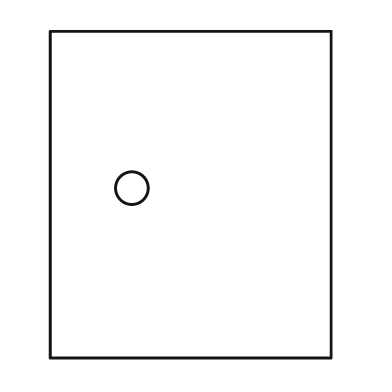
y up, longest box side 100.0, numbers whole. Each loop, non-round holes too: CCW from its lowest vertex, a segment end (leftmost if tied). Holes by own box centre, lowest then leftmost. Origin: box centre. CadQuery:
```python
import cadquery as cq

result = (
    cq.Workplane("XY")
    .moveTo(-43.0, -50.0)
    .lineTo(43.0, -50.0)
    .lineTo(43.0, 50.0)
    .lineTo(-43.0, 50.0)
    .close()
    .moveTo(-18.0, 2.0)
    .circle(5.0)
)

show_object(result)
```